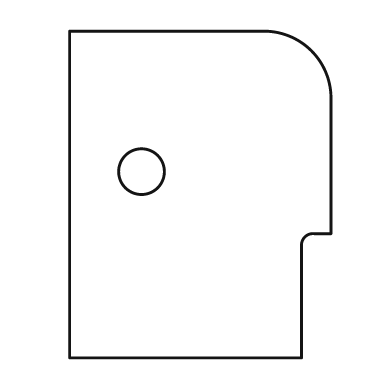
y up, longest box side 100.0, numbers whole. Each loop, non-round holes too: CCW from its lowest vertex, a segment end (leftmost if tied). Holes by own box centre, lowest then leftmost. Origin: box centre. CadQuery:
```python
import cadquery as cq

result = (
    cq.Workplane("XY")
    .moveTo(-40.0, -50.0)
    .lineTo(31.0, -50.0)
    .lineTo(31.0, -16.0)
    .threePointArc((32.0, -13.0), (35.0, -12.0))
    .lineTo(40.0, -12.0)
    .lineTo(40.0, 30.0)
    .threePointArc((34.0, 44.0), (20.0, 50.0))
    .lineTo(-40.0, 50.0)
    .close()
    .moveTo(-18.0, 7.0)
    .circle(7.0)
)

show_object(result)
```